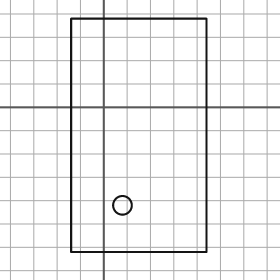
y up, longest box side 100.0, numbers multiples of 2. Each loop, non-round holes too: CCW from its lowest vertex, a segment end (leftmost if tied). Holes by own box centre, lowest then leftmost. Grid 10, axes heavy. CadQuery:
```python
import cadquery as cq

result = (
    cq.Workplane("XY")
    .moveTo(-14.0, -62.0)
    .lineTo(44.0, -62.0)
    .lineTo(44.0, 38.0)
    .lineTo(-14.0, 38.0)
    .close()
    .moveTo(8.0, -42.0)
    .circle(4.0)
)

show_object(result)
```